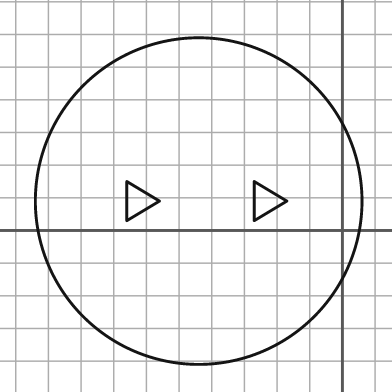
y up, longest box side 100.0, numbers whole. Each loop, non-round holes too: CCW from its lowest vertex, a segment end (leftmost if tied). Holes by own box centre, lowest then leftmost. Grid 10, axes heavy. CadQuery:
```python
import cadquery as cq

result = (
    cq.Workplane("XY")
    .moveTo(-44.0, 9.0)
    .circle(50.0)
    .moveTo(-66.0, 3.0)
    .lineTo(-56.0, 9.0)
    .lineTo(-66.0, 15.0)
    .close()
    .moveTo(-27.0, 3.0)
    .lineTo(-17.0, 9.0)
    .lineTo(-27.0, 15.0)
    .close()
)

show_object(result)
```